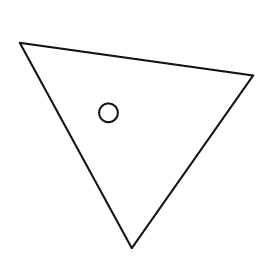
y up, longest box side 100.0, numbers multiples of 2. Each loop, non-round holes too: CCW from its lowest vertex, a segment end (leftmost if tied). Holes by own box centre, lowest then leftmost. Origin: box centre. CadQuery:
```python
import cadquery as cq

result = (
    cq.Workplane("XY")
    .moveTo(-2.0, -44.0)
    .lineTo(50.0, 30.0)
    .lineTo(-50.0, 44.0)
    .close()
    .moveTo(-12.0, 14.0)
    .circle(4.0)
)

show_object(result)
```